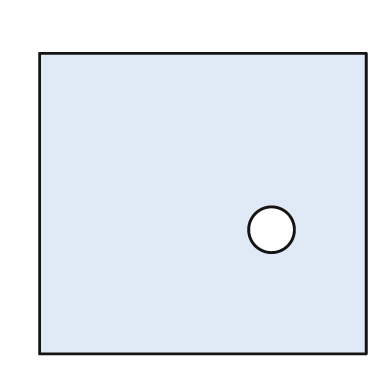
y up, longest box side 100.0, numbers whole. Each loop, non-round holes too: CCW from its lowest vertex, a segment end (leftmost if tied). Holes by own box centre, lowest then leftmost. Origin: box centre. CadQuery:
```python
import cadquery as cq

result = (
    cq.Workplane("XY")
    .moveTo(-50.0, -46.0)
    .lineTo(50.0, -46.0)
    .lineTo(50.0, 46.0)
    .lineTo(-50.0, 46.0)
    .close()
    .moveTo(21.0, -8.0)
    .circle(7.0)
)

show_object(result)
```